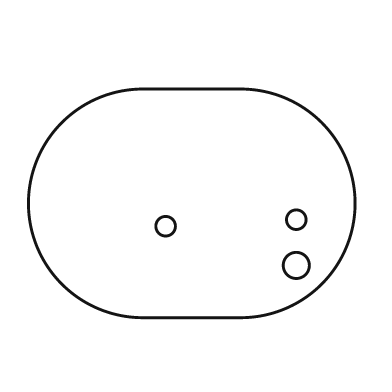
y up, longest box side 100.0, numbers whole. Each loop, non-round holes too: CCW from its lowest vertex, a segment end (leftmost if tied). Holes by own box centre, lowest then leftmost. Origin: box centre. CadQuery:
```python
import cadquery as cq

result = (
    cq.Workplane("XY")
    .moveTo(-15.0, -35.0)
    .lineTo(15.0, -35.0)
    .threePointArc((50.0, 0.0), (15.0, 35.0))
    .lineTo(-15.0, 35.0)
    .threePointArc((-50.0, 0.0), (-15.0, -35.0))
    .close()
    .moveTo(32.0, -19.0)
    .circle(4.0)
    .moveTo(-8.0, -7.0)
    .circle(3.0)
    .moveTo(32.0, -5.0)
    .circle(3.0)
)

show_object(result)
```